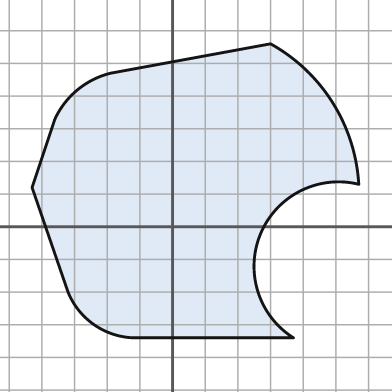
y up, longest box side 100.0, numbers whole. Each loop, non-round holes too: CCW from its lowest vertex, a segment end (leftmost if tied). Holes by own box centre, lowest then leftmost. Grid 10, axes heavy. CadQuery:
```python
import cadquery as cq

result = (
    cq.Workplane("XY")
    .moveTo(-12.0, -34.0)
    .lineTo(37.0, -34.0)
    .threePointArc((27.0, -2.0), (57.0, 13.0))
    .threePointArc((49.0, 38.0), (30.0, 56.0))
    .lineTo(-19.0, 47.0)
    .threePointArc((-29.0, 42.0), (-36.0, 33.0))
    .lineTo(-43.0, 12.0)
    .lineTo(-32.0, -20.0)
    .threePointArc((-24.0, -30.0), (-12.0, -34.0))
    .close()
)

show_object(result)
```